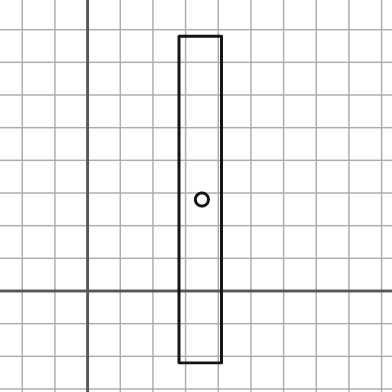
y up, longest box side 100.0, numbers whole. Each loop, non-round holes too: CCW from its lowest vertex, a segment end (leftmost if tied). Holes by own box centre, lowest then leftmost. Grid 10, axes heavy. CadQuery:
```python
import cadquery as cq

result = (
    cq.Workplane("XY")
    .moveTo(28.0, -22.0)
    .lineTo(41.0, -22.0)
    .lineTo(41.0, 78.0)
    .lineTo(28.0, 78.0)
    .close()
    .moveTo(35.0, 28.0)
    .circle(2.0)
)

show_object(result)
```